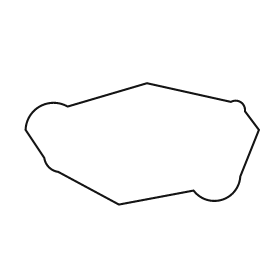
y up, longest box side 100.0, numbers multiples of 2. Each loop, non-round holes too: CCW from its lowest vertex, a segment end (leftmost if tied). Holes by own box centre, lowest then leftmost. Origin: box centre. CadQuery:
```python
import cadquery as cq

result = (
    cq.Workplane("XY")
    .moveTo(-10.0, -26.0)
    .lineTo(22.0, -20.0)
    .threePointArc((34.0, -24.0), (42.0, -14.0))
    .lineTo(50.0, 6.0)
    .lineTo(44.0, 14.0)
    .threePointArc((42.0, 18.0), (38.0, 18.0))
    .lineTo(2.0, 26.0)
    .lineTo(-32.0, 16.0)
    .threePointArc((-44.0, 16.0), (-50.0, 6.0))
    .lineTo(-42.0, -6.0)
    .threePointArc((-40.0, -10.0), (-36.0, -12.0))
    .close()
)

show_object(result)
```